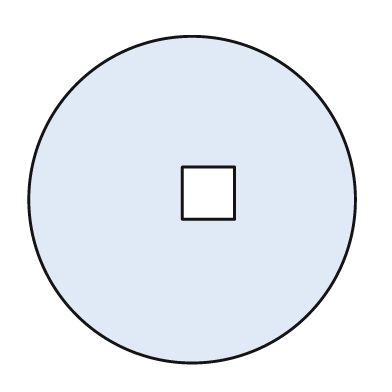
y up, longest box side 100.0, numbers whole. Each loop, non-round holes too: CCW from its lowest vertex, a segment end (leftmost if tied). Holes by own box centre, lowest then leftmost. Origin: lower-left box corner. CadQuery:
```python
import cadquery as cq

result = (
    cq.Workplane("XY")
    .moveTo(50.0, 50.0)
    .circle(50.0)
    .moveTo(47.0, 44.0)
    .lineTo(63.0, 44.0)
    .lineTo(63.0, 60.0)
    .lineTo(47.0, 60.0)
    .close()
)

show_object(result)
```